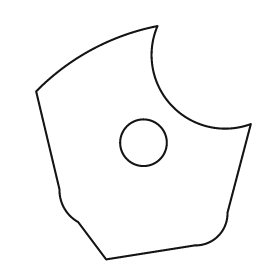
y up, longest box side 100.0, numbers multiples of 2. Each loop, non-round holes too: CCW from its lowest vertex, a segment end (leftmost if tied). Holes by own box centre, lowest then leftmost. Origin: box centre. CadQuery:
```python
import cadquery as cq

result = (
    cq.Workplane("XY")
    .moveTo(-16.0, -50.0)
    .lineTo(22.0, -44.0)
    .threePointArc((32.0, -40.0), (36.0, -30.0))
    .lineTo(46.0, 8.0)
    .threePointArc((12.0, 16.0), (6.0, 50.0))
    .threePointArc((-22.0, 40.0), (-46.0, 22.0))
    .lineTo(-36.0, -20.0)
    .threePointArc((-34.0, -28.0), (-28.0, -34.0))
    .close()
    .moveTo(0.0, 0.0)
    .circle(10.0)
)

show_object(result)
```